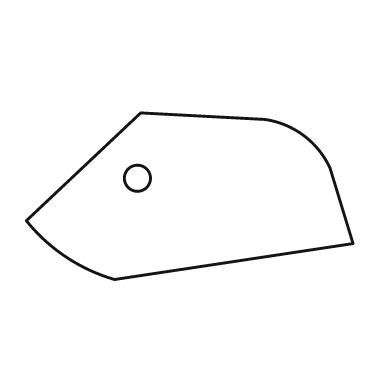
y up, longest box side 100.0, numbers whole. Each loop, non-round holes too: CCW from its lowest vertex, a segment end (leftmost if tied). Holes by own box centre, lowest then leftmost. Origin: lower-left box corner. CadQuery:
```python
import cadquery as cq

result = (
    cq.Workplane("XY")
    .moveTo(27.0, 0.0)
    .lineTo(100.0, 11.0)
    .lineTo(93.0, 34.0)
    .threePointArc((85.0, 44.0), (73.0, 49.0))
    .lineTo(35.0, 51.0)
    .lineTo(0.0, 18.0)
    .threePointArc((12.0, 7.0), (27.0, 0.0))
    .close()
    .moveTo(34.0, 31.0)
    .circle(4.0)
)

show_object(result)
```